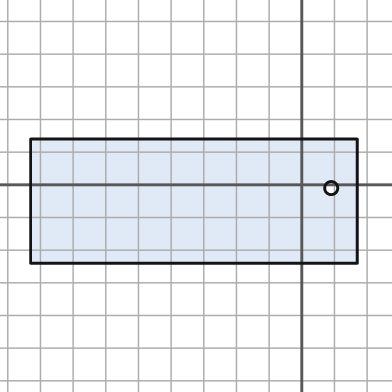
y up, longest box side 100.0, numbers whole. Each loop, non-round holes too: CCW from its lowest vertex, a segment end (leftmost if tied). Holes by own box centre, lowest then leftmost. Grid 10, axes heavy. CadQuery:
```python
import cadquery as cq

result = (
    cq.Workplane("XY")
    .moveTo(-83.0, -24.0)
    .lineTo(17.0, -24.0)
    .lineTo(17.0, 14.0)
    .lineTo(-83.0, 14.0)
    .close()
    .moveTo(9.0, -1.0)
    .circle(2.0)
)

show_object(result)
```